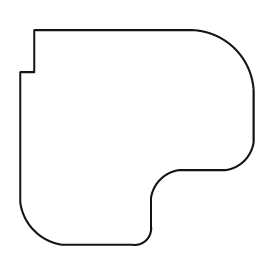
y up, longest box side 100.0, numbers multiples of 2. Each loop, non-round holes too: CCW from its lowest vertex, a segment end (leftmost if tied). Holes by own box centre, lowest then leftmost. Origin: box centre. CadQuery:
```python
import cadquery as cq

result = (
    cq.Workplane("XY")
    .moveTo(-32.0, -46.0)
    .lineTo(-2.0, -46.0)
    .threePointArc((4.0, -44.0), (6.0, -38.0))
    .lineTo(6.0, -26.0)
    .threePointArc((10.0, -18.0), (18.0, -14.0))
    .lineTo(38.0, -14.0)
    .threePointArc((46.0, -10.0), (50.0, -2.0))
    .lineTo(50.0, 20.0)
    .threePointArc((42.0, 38.0), (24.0, 46.0))
    .lineTo(-44.0, 46.0)
    .lineTo(-44.0, 28.0)
    .lineTo(-50.0, 28.0)
    .lineTo(-50.0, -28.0)
    .threePointArc((-44.0, -40.0), (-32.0, -46.0))
    .close()
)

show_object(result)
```